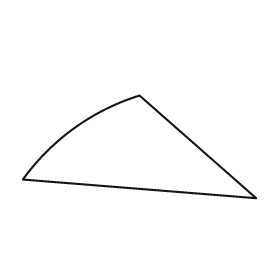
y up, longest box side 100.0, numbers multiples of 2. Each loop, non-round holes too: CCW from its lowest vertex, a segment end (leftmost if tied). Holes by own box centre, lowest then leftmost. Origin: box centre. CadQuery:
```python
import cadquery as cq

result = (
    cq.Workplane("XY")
    .moveTo(50.0, -22.0)
    .lineTo(0.0, 22.0)
    .threePointArc((-28.0, 8.0), (-50.0, -14.0))
    .close()
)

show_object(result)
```